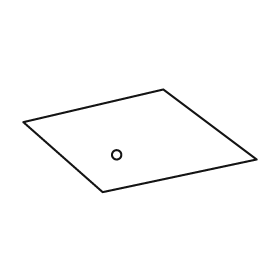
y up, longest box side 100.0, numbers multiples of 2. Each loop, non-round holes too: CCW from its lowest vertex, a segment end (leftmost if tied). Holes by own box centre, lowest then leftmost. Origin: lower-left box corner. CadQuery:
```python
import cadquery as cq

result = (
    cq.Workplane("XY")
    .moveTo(34.0, 0.0)
    .lineTo(100.0, 14.0)
    .lineTo(60.0, 44.0)
    .lineTo(0.0, 30.0)
    .close()
    .moveTo(40.0, 16.0)
    .circle(2.0)
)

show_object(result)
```